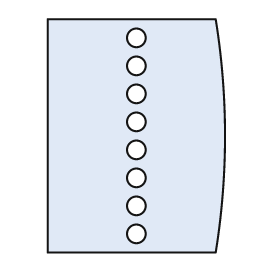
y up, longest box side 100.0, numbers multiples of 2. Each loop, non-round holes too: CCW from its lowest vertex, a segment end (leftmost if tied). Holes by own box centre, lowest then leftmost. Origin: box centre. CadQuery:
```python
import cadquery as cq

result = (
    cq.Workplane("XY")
    .moveTo(-38.0, -50.0)
    .lineTo(34.0, -50.0)
    .threePointArc((38.0, 0.0), (34.0, 50.0))
    .lineTo(-38.0, 50.0)
    .close()
    .moveTo(0.0, -42.0)
    .circle(4.0)
    .moveTo(0.0, -30.0)
    .circle(4.0)
    .moveTo(0.0, -18.0)
    .circle(4.0)
    .moveTo(0.0, -6.0)
    .circle(4.0)
    .moveTo(0.0, 6.0)
    .circle(4.0)
    .moveTo(0.0, 18.0)
    .circle(4.0)
    .moveTo(0.0, 30.0)
    .circle(4.0)
    .moveTo(0.0, 42.0)
    .circle(4.0)
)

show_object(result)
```